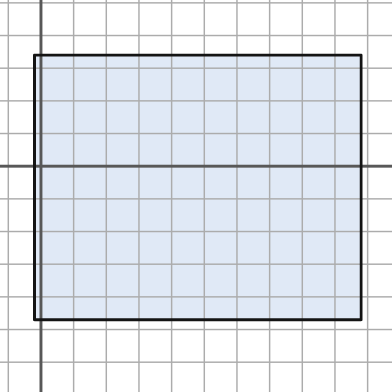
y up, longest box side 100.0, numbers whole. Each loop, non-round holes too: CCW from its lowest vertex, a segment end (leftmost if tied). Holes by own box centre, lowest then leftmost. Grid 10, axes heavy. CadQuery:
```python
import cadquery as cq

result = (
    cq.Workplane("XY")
    .moveTo(-2.0, -47.0)
    .lineTo(98.0, -47.0)
    .lineTo(98.0, 34.0)
    .lineTo(-2.0, 34.0)
    .close()
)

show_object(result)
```